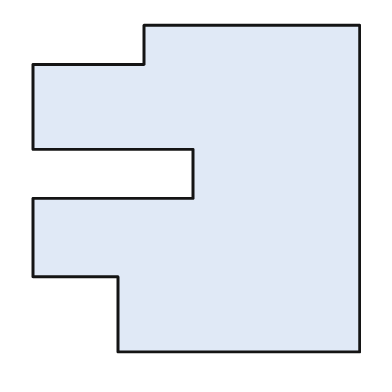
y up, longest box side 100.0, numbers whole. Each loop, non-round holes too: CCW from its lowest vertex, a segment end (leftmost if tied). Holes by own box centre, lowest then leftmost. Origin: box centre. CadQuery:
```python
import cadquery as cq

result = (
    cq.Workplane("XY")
    .moveTo(-24.0, -50.0)
    .lineTo(50.0, -50.0)
    .lineTo(50.0, 50.0)
    .lineTo(-16.0, 50.0)
    .lineTo(-16.0, 38.0)
    .lineTo(-50.0, 38.0)
    .lineTo(-50.0, 12.0)
    .lineTo(-1.0, 12.0)
    .lineTo(-1.0, -3.0)
    .lineTo(-50.0, -3.0)
    .lineTo(-50.0, -27.0)
    .lineTo(-24.0, -27.0)
    .close()
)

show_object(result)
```